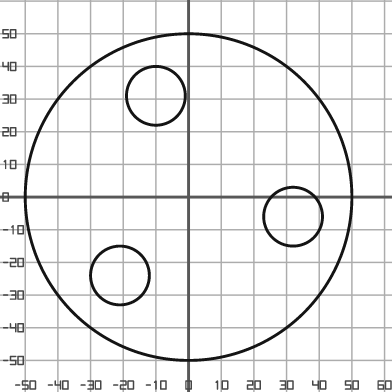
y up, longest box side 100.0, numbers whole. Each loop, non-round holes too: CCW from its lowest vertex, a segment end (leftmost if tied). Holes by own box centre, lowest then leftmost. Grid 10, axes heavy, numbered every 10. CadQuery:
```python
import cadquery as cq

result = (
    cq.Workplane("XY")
    .moveTo(0.0, 0.0)
    .circle(50.0)
    .moveTo(-21.0, -24.0)
    .circle(9.0)
    .moveTo(32.0, -6.0)
    .circle(9.0)
    .moveTo(-10.0, 31.0)
    .circle(9.0)
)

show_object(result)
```